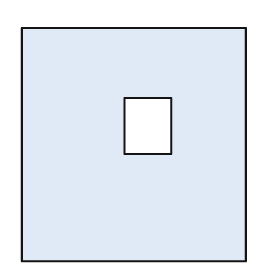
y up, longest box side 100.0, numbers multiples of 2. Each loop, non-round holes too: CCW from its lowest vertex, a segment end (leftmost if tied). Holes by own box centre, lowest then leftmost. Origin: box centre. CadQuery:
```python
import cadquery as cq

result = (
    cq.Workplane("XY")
    .moveTo(-48.0, -50.0)
    .lineTo(48.0, -50.0)
    .lineTo(48.0, 50.0)
    .lineTo(-48.0, 50.0)
    .close()
    .moveTo(-4.0, -4.0)
    .lineTo(16.0, -4.0)
    .lineTo(16.0, 20.0)
    .lineTo(-4.0, 20.0)
    .close()
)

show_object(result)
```